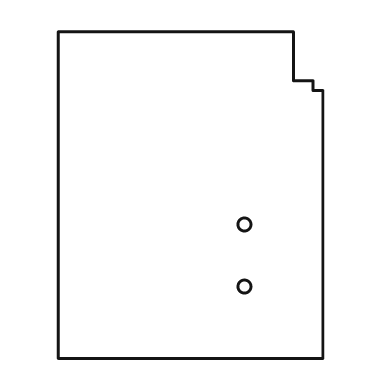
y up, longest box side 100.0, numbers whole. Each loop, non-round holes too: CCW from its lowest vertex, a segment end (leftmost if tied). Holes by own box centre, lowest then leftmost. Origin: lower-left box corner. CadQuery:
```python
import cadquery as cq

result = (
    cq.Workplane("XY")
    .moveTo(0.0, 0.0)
    .lineTo(81.0, 0.0)
    .lineTo(81.0, 82.0)
    .lineTo(78.0, 82.0)
    .lineTo(78.0, 85.0)
    .lineTo(72.0, 85.0)
    .lineTo(72.0, 100.0)
    .lineTo(0.0, 100.0)
    .close()
    .moveTo(57.0, 22.0)
    .circle(2.0)
    .moveTo(57.0, 41.0)
    .circle(2.0)
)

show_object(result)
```